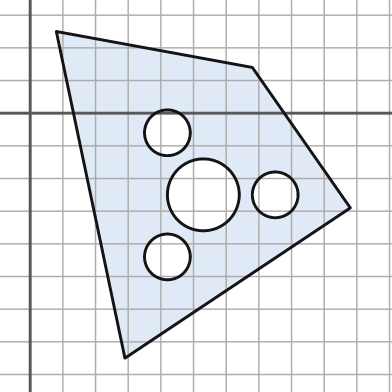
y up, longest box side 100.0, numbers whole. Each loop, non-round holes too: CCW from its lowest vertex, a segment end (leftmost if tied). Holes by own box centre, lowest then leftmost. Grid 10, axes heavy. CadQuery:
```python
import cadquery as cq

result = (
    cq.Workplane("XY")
    .moveTo(29.0, -75.0)
    .lineTo(98.0, -29.0)
    .lineTo(68.0, 14.0)
    .lineTo(8.0, 25.0)
    .close()
    .moveTo(42.0, -44.0)
    .circle(7.0)
    .moveTo(53.0, -25.0)
    .circle(11.0)
    .moveTo(75.0, -25.0)
    .circle(7.0)
    .moveTo(42.0, -6.0)
    .circle(7.0)
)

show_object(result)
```